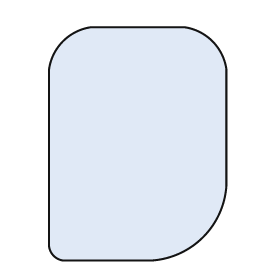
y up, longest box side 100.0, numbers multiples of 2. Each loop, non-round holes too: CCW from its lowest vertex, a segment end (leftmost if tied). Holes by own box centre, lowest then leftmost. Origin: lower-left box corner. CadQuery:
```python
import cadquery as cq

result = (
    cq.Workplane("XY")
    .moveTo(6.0, 0.0)
    .lineTo(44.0, 0.0)
    .threePointArc((66.0, 10.0), (76.0, 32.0))
    .lineTo(76.0, 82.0)
    .threePointArc((70.0, 94.0), (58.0, 100.0))
    .lineTo(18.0, 100.0)
    .threePointArc((6.0, 94.0), (0.0, 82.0))
    .lineTo(0.0, 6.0)
    .threePointArc((2.0, 2.0), (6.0, 0.0))
    .close()
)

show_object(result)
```